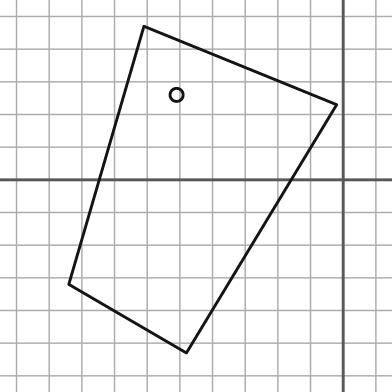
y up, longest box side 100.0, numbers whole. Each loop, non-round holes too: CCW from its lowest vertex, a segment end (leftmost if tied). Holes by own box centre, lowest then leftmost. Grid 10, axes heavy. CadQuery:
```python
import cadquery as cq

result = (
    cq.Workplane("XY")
    .moveTo(-48.0, -53.0)
    .lineTo(-2.0, 23.0)
    .lineTo(-61.0, 47.0)
    .lineTo(-84.0, -32.0)
    .close()
    .moveTo(-51.0, 26.0)
    .circle(2.0)
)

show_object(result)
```